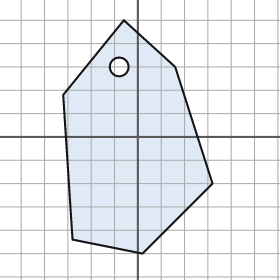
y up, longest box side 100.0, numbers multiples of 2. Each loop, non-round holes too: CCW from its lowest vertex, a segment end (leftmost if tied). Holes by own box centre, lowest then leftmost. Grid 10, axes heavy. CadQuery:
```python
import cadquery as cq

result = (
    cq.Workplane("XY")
    .moveTo(2.0, -50.0)
    .lineTo(32.0, -20.0)
    .lineTo(16.0, 30.0)
    .lineTo(-6.0, 50.0)
    .lineTo(-32.0, 18.0)
    .lineTo(-28.0, -44.0)
    .close()
    .moveTo(-8.0, 30.0)
    .circle(4.0)
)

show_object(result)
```